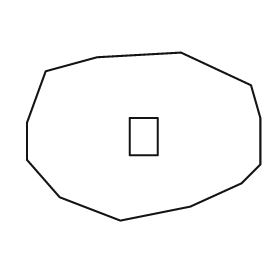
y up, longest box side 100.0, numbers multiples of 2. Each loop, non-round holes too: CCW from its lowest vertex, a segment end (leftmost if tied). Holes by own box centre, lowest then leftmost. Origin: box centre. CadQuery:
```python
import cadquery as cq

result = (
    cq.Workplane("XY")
    .moveTo(-10.0, -36.0)
    .lineTo(20.0, -30.0)
    .lineTo(42.0, -20.0)
    .lineTo(50.0, -12.0)
    .lineTo(50.0, 8.0)
    .lineTo(46.0, 22.0)
    .lineTo(16.0, 36.0)
    .lineTo(-20.0, 34.0)
    .lineTo(-42.0, 28.0)
    .lineTo(-50.0, 6.0)
    .lineTo(-50.0, -10.0)
    .lineTo(-36.0, -26.0)
    .close()
    .moveTo(-6.0, -8.0)
    .lineTo(6.0, -8.0)
    .lineTo(6.0, 8.0)
    .lineTo(-6.0, 8.0)
    .close()
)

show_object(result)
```